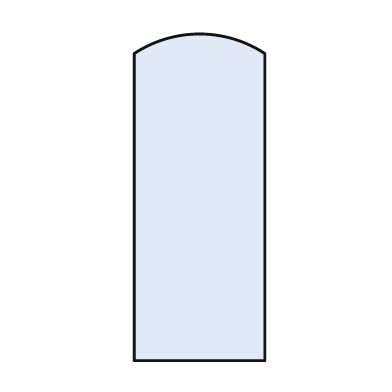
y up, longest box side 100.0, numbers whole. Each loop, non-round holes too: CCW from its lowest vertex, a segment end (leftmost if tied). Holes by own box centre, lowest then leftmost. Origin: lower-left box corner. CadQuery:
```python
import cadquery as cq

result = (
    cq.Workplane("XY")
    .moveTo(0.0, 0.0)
    .lineTo(40.0, 0.0)
    .lineTo(40.0, 94.0)
    .threePointArc((20.0, 100.0), (0.0, 94.0))
    .close()
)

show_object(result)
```